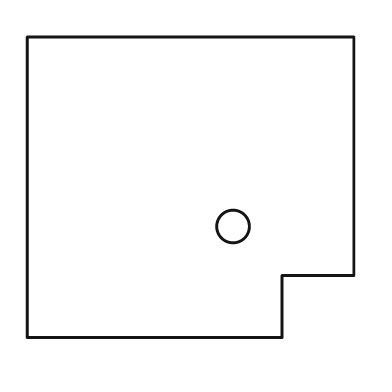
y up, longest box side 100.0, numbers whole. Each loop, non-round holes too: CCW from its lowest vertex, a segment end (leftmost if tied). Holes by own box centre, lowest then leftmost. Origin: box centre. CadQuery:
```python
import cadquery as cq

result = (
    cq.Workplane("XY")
    .moveTo(-50.0, -46.0)
    .lineTo(28.0, -46.0)
    .lineTo(28.0, -27.0)
    .lineTo(50.0, -27.0)
    .lineTo(50.0, 46.0)
    .lineTo(-50.0, 46.0)
    .close()
    .moveTo(13.0, -12.0)
    .circle(5.0)
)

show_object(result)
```